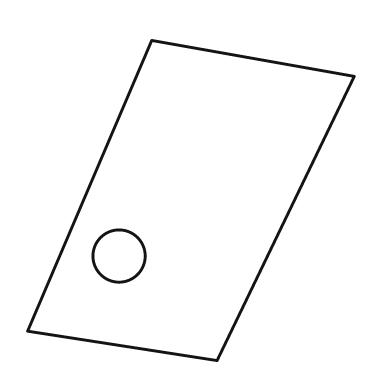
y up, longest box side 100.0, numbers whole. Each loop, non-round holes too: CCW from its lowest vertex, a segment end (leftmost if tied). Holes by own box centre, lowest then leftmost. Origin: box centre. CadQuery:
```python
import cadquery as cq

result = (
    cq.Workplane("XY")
    .moveTo(8.0, -49.0)
    .lineTo(50.0, 38.0)
    .lineTo(-12.0, 49.0)
    .lineTo(-50.0, -40.0)
    .close()
    .moveTo(-22.0, -17.0)
    .circle(8.0)
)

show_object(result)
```